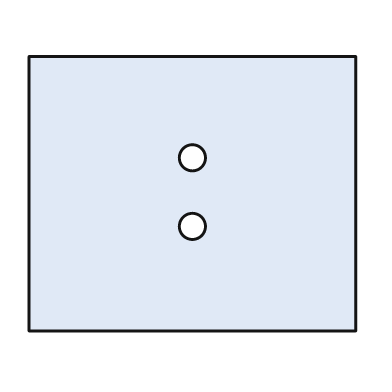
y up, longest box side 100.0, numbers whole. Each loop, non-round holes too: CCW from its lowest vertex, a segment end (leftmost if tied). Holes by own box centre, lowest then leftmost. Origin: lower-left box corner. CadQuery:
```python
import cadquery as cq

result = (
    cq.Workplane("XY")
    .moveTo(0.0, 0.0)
    .lineTo(100.0, 0.0)
    .lineTo(100.0, 84.0)
    .lineTo(0.0, 84.0)
    .close()
    .moveTo(50.0, 32.0)
    .circle(4.0)
    .moveTo(50.0, 53.0)
    .circle(4.0)
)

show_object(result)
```